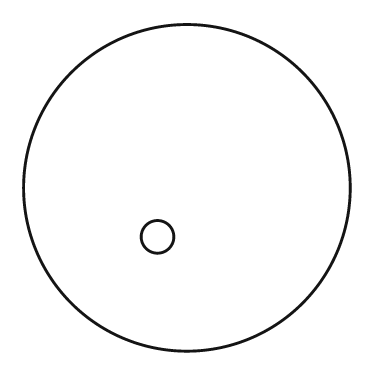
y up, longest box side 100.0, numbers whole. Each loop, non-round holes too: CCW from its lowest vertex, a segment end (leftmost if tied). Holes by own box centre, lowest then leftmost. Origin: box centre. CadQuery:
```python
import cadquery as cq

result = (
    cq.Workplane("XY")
    .moveTo(0.0, 0.0)
    .circle(50.0)
    .moveTo(-9.0, -15.0)
    .circle(5.0)
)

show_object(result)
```